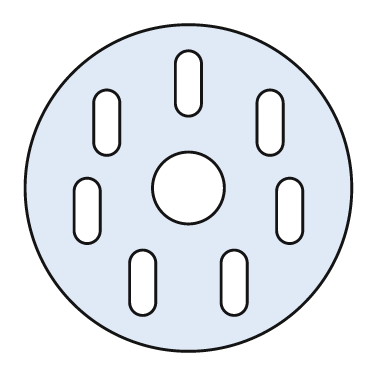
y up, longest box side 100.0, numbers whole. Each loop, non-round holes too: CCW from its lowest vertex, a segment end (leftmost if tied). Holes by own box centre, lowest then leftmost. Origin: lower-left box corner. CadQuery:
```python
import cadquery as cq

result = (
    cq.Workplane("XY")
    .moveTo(50.0, 50.0)
    .circle(50.0)
    .moveTo(32.0, 15.0)
    .threePointArc((36.0, 11.0), (40.0, 15.0))
    .lineTo(40.0, 27.0)
    .threePointArc((36.0, 31.0), (32.0, 27.0))
    .close()
    .moveTo(60.0, 15.0)
    .threePointArc((64.0, 11.0), (68.0, 15.0))
    .lineTo(68.0, 27.0)
    .threePointArc((64.0, 31.0), (60.0, 27.0))
    .close()
    .moveTo(15.0, 37.0)
    .threePointArc((19.0, 33.0), (23.0, 37.0))
    .lineTo(23.0, 49.0)
    .threePointArc((19.0, 53.0), (15.0, 49.0))
    .close()
    .moveTo(77.0, 37.0)
    .threePointArc((81.0, 33.0), (85.0, 37.0))
    .lineTo(85.0, 49.0)
    .threePointArc((81.0, 53.0), (77.0, 49.0))
    .close()
    .moveTo(50.0, 50.0)
    .circle(11.0)
    .moveTo(21.0, 64.0)
    .threePointArc((25.0, 60.0), (29.0, 64.0))
    .lineTo(29.0, 76.0)
    .threePointArc((25.0, 80.0), (21.0, 76.0))
    .close()
    .moveTo(71.0, 64.0)
    .threePointArc((75.0, 60.0), (79.0, 64.0))
    .lineTo(79.0, 76.0)
    .threePointArc((75.0, 80.0), (71.0, 76.0))
    .close()
    .moveTo(46.0, 76.0)
    .threePointArc((50.0, 72.0), (54.0, 76.0))
    .lineTo(54.0, 88.0)
    .threePointArc((50.0, 92.0), (46.0, 88.0))
    .close()
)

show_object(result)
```